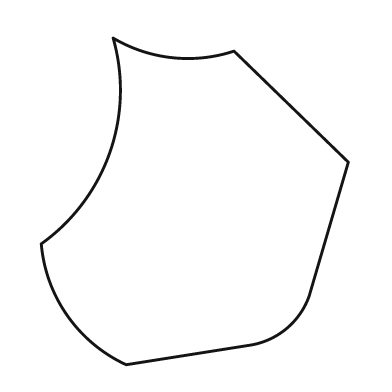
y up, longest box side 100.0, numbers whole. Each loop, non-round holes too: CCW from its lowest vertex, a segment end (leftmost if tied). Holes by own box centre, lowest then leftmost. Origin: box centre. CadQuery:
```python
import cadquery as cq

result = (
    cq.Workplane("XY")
    .moveTo(-21.0, -50.0)
    .lineTo(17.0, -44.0)
    .threePointArc((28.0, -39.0), (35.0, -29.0))
    .lineTo(47.0, 12.0)
    .lineTo(12.0, 46.0)
    .threePointArc((-7.0, 44.0), (-25.0, 50.0))
    .threePointArc((-26.0, 15.0), (-47.0, -13.0))
    .threePointArc((-39.0, -35.0), (-21.0, -50.0))
    .close()
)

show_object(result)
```